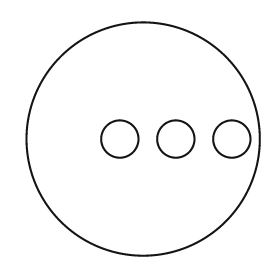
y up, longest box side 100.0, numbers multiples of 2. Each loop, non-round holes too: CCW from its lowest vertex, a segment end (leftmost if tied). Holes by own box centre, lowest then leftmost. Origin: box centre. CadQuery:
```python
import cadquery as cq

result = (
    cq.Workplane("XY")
    .moveTo(0.0, 0.0)
    .circle(50.0)
    .moveTo(-10.0, 0.0)
    .circle(8.0)
    .moveTo(14.0, 0.0)
    .circle(8.0)
    .moveTo(38.0, 0.0)
    .circle(8.0)
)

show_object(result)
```